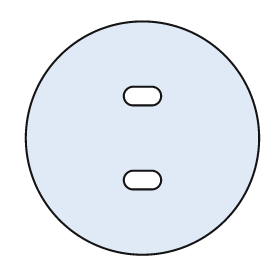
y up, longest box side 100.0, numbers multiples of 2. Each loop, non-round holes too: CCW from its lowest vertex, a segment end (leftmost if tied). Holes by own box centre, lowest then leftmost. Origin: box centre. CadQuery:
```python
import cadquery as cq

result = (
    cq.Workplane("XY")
    .moveTo(0.0, 0.0)
    .circle(50.0)
    .moveTo(-4.0, -22.0)
    .lineTo(4.0, -22.0)
    .threePointArc((8.0, -18.0), (4.0, -14.0))
    .lineTo(-4.0, -14.0)
    .threePointArc((-8.0, -18.0), (-4.0, -22.0))
    .close()
    .moveTo(-4.0, 14.0)
    .lineTo(4.0, 14.0)
    .threePointArc((8.0, 18.0), (4.0, 22.0))
    .lineTo(-4.0, 22.0)
    .threePointArc((-8.0, 18.0), (-4.0, 14.0))
    .close()
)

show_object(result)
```